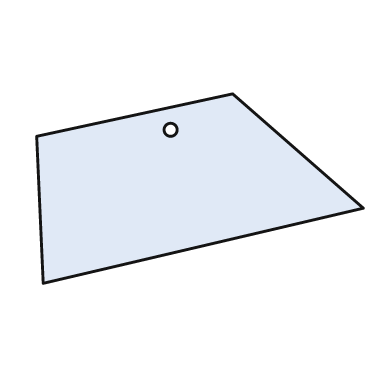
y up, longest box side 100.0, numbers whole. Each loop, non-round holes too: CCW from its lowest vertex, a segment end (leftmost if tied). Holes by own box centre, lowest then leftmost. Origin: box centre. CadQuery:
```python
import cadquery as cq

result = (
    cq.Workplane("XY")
    .moveTo(-48.0, -29.0)
    .lineTo(50.0, -6.0)
    .lineTo(10.0, 29.0)
    .lineTo(-50.0, 16.0)
    .close()
    .moveTo(-9.0, 18.0)
    .circle(2.0)
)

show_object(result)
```